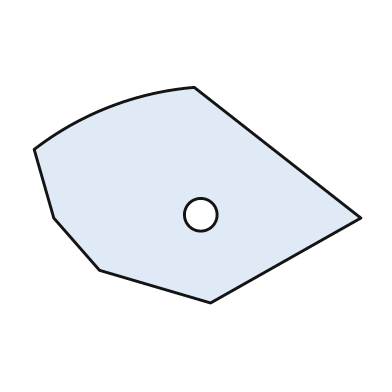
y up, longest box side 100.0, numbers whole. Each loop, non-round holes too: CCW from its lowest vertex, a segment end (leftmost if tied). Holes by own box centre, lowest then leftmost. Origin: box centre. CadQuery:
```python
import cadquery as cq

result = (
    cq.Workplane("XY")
    .moveTo(4.0, -33.0)
    .lineTo(50.0, -7.0)
    .lineTo(-1.0, 33.0)
    .threePointArc((-27.0, 27.0), (-50.0, 14.0))
    .lineTo(-44.0, -7.0)
    .lineTo(-30.0, -23.0)
    .close()
    .moveTo(1.0, -6.0)
    .circle(5.0)
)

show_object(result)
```